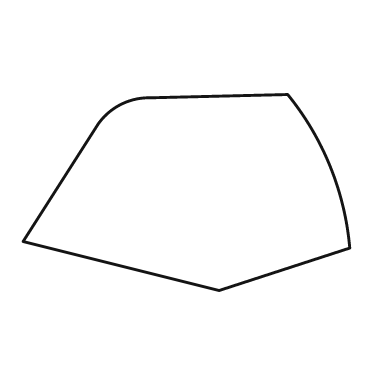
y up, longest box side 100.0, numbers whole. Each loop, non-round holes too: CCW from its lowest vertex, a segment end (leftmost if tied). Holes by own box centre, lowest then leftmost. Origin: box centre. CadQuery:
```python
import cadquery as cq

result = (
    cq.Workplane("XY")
    .moveTo(10.0, -30.0)
    .lineTo(50.0, -17.0)
    .threePointArc((44.0, 8.0), (31.0, 30.0))
    .lineTo(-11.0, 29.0)
    .threePointArc((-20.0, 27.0), (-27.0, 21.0))
    .lineTo(-50.0, -15.0)
    .close()
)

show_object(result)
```